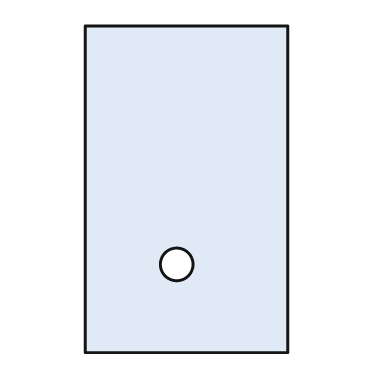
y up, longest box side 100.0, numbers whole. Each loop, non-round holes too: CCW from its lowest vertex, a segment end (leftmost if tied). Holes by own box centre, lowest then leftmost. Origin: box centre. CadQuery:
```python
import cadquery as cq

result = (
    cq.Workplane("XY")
    .moveTo(-31.0, -50.0)
    .lineTo(31.0, -50.0)
    .lineTo(31.0, 50.0)
    .lineTo(-31.0, 50.0)
    .close()
    .moveTo(-3.0, -23.0)
    .circle(5.0)
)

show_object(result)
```